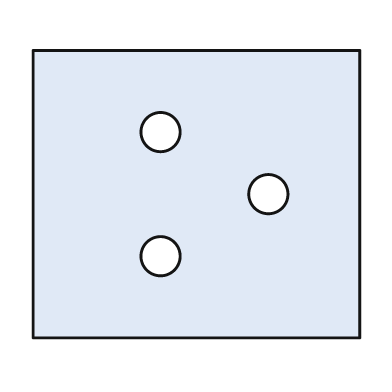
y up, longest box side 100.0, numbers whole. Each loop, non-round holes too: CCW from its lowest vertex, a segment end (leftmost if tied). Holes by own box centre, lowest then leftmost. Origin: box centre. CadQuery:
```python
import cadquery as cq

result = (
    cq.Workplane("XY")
    .moveTo(-50.0, -44.0)
    .lineTo(50.0, -44.0)
    .lineTo(50.0, 44.0)
    .lineTo(-50.0, 44.0)
    .close()
    .moveTo(-11.0, -19.0)
    .circle(6.0)
    .moveTo(22.0, 0.0)
    .circle(6.0)
    .moveTo(-11.0, 19.0)
    .circle(6.0)
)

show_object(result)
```